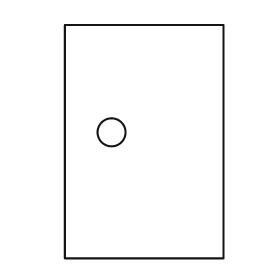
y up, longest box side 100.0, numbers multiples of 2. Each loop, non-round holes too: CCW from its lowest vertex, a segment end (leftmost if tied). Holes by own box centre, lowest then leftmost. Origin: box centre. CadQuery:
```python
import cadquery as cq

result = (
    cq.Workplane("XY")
    .moveTo(-34.0, -50.0)
    .lineTo(34.0, -50.0)
    .lineTo(34.0, 50.0)
    .lineTo(-34.0, 50.0)
    .close()
    .moveTo(-14.0, 4.0)
    .circle(6.0)
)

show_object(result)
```